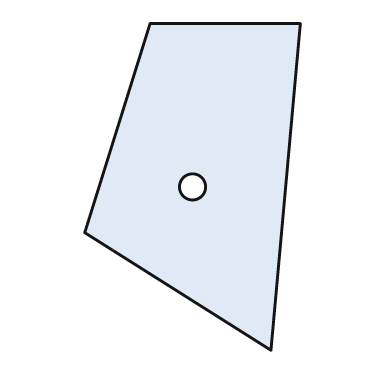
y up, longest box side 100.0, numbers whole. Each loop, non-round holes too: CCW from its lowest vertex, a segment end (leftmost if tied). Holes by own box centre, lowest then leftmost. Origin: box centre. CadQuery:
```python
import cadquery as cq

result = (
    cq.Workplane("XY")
    .moveTo(24.0, -50.0)
    .lineTo(33.0, 50.0)
    .lineTo(-13.0, 50.0)
    .lineTo(-33.0, -14.0)
    .close()
    .moveTo(0.0, 0.0)
    .circle(4.0)
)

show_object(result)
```